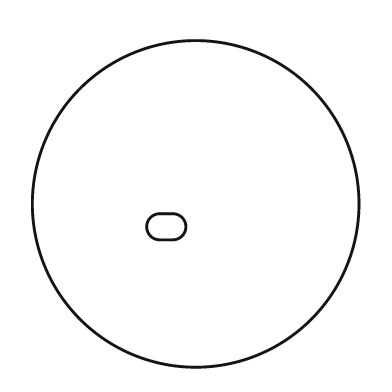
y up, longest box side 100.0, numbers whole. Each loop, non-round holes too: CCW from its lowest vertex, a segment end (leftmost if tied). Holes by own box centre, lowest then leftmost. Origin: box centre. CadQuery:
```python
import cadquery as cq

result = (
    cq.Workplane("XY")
    .moveTo(0.0, 0.0)
    .circle(50.0)
    .moveTo(-11.0, -11.0)
    .lineTo(-7.0, -11.0)
    .threePointArc((-3.0, -7.0), (-7.0, -3.0))
    .lineTo(-11.0, -3.0)
    .threePointArc((-15.0, -7.0), (-11.0, -11.0))
    .close()
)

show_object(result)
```